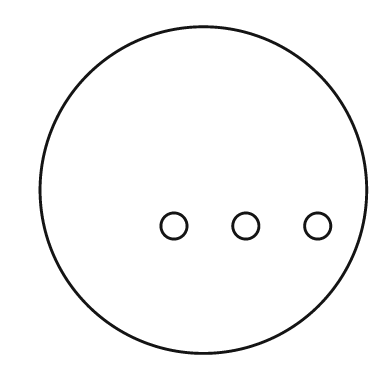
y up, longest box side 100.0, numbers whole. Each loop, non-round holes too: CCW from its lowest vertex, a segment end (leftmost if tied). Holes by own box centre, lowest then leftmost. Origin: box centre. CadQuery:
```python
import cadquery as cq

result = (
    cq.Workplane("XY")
    .moveTo(0.0, 0.0)
    .circle(50.0)
    .moveTo(-9.0, -11.0)
    .circle(4.0)
    .moveTo(13.0, -11.0)
    .circle(4.0)
    .moveTo(35.0, -11.0)
    .circle(4.0)
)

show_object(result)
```